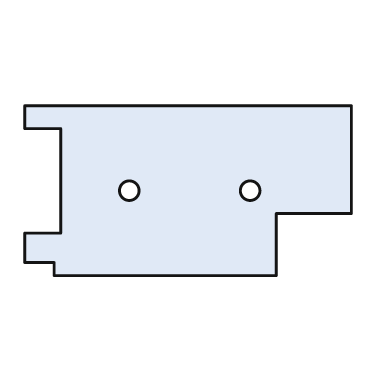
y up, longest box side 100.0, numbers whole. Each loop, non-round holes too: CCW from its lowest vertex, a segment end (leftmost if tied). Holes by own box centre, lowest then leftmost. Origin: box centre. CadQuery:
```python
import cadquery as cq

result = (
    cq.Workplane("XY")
    .moveTo(-41.0, -26.0)
    .lineTo(27.0, -26.0)
    .lineTo(27.0, -7.0)
    .lineTo(50.0, -7.0)
    .lineTo(50.0, 26.0)
    .lineTo(-50.0, 26.0)
    .lineTo(-50.0, 19.0)
    .lineTo(-39.0, 19.0)
    .lineTo(-39.0, -13.0)
    .lineTo(-50.0, -13.0)
    .lineTo(-50.0, -22.0)
    .lineTo(-41.0, -22.0)
    .close()
    .moveTo(-18.0, 0.0)
    .circle(3.0)
    .moveTo(19.0, 0.0)
    .circle(3.0)
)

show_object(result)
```